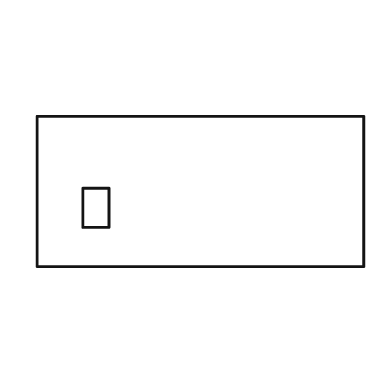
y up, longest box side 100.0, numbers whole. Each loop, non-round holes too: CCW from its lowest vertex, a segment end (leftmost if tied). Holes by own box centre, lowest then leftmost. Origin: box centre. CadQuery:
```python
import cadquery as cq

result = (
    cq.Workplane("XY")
    .moveTo(-50.0, -23.0)
    .lineTo(50.0, -23.0)
    .lineTo(50.0, 23.0)
    .lineTo(-50.0, 23.0)
    .close()
    .moveTo(-36.0, -11.0)
    .lineTo(-28.0, -11.0)
    .lineTo(-28.0, 1.0)
    .lineTo(-36.0, 1.0)
    .close()
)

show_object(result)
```